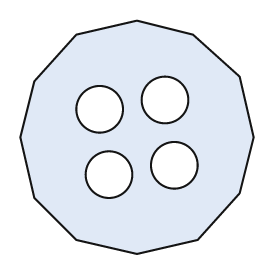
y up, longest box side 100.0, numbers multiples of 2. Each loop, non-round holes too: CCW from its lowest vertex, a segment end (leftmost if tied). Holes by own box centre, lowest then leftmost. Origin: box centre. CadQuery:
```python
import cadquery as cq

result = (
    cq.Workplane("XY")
    .moveTo(0.0, -50.0)
    .lineTo(26.0, -44.0)
    .lineTo(44.0, -24.0)
    .lineTo(50.0, 0.0)
    .lineTo(44.0, 26.0)
    .lineTo(24.0, 44.0)
    .lineTo(0.0, 50.0)
    .lineTo(-26.0, 44.0)
    .lineTo(-44.0, 24.0)
    .lineTo(-50.0, 0.0)
    .lineTo(-44.0, -26.0)
    .lineTo(-26.0, -44.0)
    .close()
    .moveTo(-12.0, -16.0)
    .circle(10.0)
    .moveTo(16.0, -12.0)
    .circle(10.0)
    .moveTo(-16.0, 12.0)
    .circle(10.0)
    .moveTo(12.0, 16.0)
    .circle(10.0)
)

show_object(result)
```